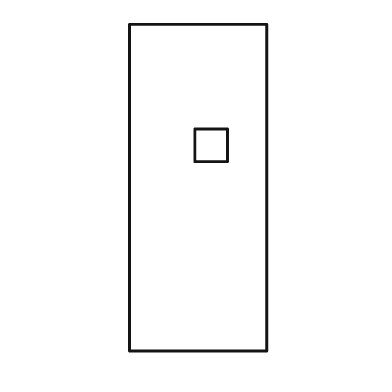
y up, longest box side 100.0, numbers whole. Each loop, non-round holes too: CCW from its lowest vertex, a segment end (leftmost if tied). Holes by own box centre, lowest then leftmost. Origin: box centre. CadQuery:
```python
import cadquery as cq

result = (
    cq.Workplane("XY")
    .moveTo(-21.0, -50.0)
    .lineTo(21.0, -50.0)
    .lineTo(21.0, 50.0)
    .lineTo(-21.0, 50.0)
    .close()
    .moveTo(-1.0, 8.0)
    .lineTo(9.0, 8.0)
    .lineTo(9.0, 18.0)
    .lineTo(-1.0, 18.0)
    .close()
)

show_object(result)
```